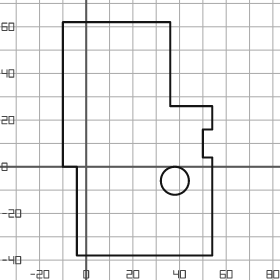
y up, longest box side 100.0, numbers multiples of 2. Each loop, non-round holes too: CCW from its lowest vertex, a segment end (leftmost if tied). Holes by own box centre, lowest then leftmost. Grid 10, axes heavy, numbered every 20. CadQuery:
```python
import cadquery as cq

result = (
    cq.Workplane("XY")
    .moveTo(-4.0, -38.0)
    .lineTo(54.0, -38.0)
    .lineTo(54.0, 4.0)
    .lineTo(50.0, 4.0)
    .lineTo(50.0, 16.0)
    .lineTo(54.0, 16.0)
    .lineTo(54.0, 26.0)
    .lineTo(36.0, 26.0)
    .lineTo(36.0, 62.0)
    .lineTo(-10.0, 62.0)
    .lineTo(-10.0, 0.0)
    .lineTo(-4.0, 0.0)
    .close()
    .moveTo(38.0, -6.0)
    .circle(6.0)
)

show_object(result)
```